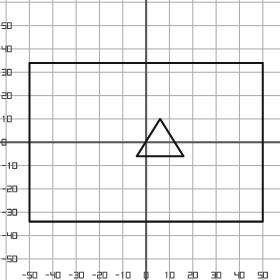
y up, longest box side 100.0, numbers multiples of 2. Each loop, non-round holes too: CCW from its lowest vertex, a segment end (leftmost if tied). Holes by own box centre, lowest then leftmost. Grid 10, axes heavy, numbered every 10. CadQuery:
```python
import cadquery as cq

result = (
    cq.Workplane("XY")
    .moveTo(-50.0, -34.0)
    .lineTo(50.0, -34.0)
    .lineTo(50.0, 34.0)
    .lineTo(-50.0, 34.0)
    .close()
    .moveTo(-4.0, -6.0)
    .lineTo(16.0, -6.0)
    .lineTo(6.0, 10.0)
    .close()
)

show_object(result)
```